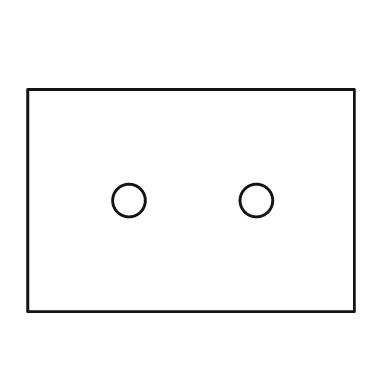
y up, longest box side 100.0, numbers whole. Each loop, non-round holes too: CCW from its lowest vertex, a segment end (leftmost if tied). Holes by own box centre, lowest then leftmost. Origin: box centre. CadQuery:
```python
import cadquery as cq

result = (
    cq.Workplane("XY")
    .moveTo(-50.0, -34.0)
    .lineTo(50.0, -34.0)
    .lineTo(50.0, 34.0)
    .lineTo(-50.0, 34.0)
    .close()
    .moveTo(-19.0, 0.0)
    .circle(5.0)
    .moveTo(20.0, 0.0)
    .circle(5.0)
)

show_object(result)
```